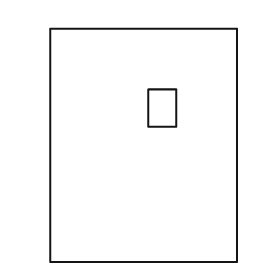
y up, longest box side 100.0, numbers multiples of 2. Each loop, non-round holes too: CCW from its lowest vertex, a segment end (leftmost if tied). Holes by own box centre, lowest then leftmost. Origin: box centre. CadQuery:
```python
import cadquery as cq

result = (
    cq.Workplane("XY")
    .moveTo(-40.0, -50.0)
    .lineTo(40.0, -50.0)
    .lineTo(40.0, 50.0)
    .lineTo(-40.0, 50.0)
    .close()
    .moveTo(2.0, 8.0)
    .lineTo(14.0, 8.0)
    .lineTo(14.0, 24.0)
    .lineTo(2.0, 24.0)
    .close()
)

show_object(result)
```